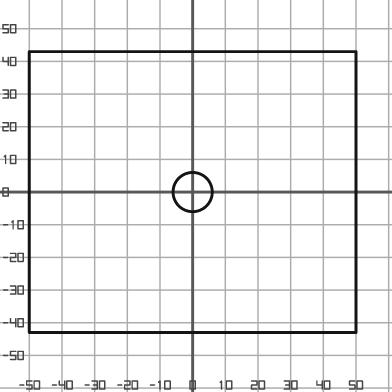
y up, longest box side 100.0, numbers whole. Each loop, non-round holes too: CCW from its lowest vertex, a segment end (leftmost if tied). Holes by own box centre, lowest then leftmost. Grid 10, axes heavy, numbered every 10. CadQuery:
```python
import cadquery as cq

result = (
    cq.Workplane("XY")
    .moveTo(-50.0, -43.0)
    .lineTo(50.0, -43.0)
    .lineTo(50.0, 43.0)
    .lineTo(-50.0, 43.0)
    .close()
    .moveTo(0.0, 0.0)
    .circle(6.0)
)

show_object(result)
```